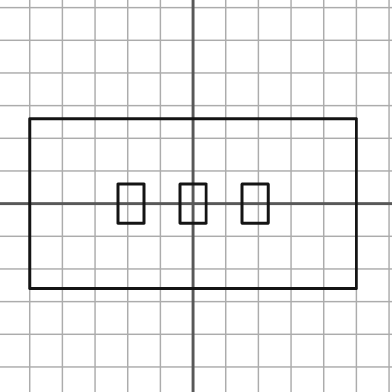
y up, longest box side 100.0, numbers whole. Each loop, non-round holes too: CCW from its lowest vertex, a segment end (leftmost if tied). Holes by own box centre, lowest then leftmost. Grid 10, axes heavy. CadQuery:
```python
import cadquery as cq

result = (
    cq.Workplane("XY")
    .moveTo(-50.0, -26.0)
    .lineTo(50.0, -26.0)
    .lineTo(50.0, 26.0)
    .lineTo(-50.0, 26.0)
    .close()
    .moveTo(-23.0, -6.0)
    .lineTo(-15.0, -6.0)
    .lineTo(-15.0, 6.0)
    .lineTo(-23.0, 6.0)
    .close()
    .moveTo(-4.0, -6.0)
    .lineTo(4.0, -6.0)
    .lineTo(4.0, 6.0)
    .lineTo(-4.0, 6.0)
    .close()
    .moveTo(15.0, -6.0)
    .lineTo(23.0, -6.0)
    .lineTo(23.0, 6.0)
    .lineTo(15.0, 6.0)
    .close()
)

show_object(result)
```